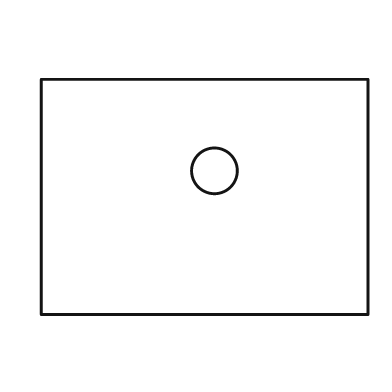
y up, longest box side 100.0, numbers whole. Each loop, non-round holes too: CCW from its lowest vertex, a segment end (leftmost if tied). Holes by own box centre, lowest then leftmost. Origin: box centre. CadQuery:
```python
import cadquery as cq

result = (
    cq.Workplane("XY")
    .moveTo(-50.0, -36.0)
    .lineTo(50.0, -36.0)
    .lineTo(50.0, 36.0)
    .lineTo(-50.0, 36.0)
    .close()
    .moveTo(3.0, 8.0)
    .circle(7.0)
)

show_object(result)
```